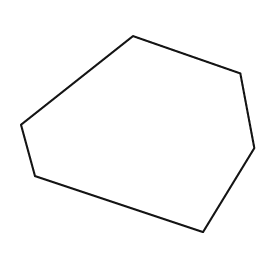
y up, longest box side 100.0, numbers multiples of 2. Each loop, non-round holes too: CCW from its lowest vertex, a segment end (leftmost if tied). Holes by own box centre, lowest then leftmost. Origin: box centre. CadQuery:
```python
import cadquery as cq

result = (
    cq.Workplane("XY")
    .moveTo(28.0, -42.0)
    .lineTo(50.0, -6.0)
    .lineTo(44.0, 26.0)
    .lineTo(-2.0, 42.0)
    .lineTo(-50.0, 4.0)
    .lineTo(-44.0, -18.0)
    .close()
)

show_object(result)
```